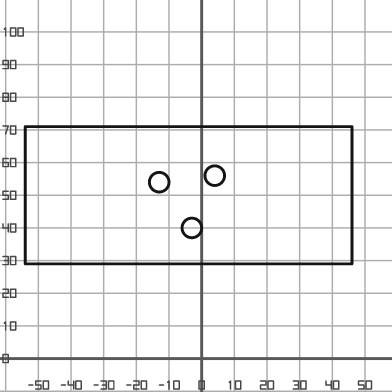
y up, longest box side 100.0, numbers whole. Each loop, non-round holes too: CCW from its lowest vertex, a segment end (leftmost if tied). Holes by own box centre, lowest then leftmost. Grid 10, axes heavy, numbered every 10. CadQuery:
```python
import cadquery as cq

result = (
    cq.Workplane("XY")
    .moveTo(-54.0, 29.0)
    .lineTo(46.0, 29.0)
    .lineTo(46.0, 71.0)
    .lineTo(-54.0, 71.0)
    .close()
    .moveTo(-3.0, 40.0)
    .circle(3.0)
    .moveTo(-13.0, 54.0)
    .circle(3.0)
    .moveTo(4.0, 56.0)
    .circle(3.0)
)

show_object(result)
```